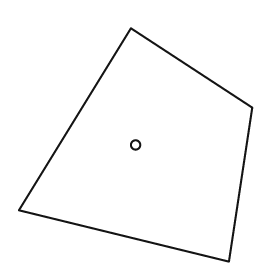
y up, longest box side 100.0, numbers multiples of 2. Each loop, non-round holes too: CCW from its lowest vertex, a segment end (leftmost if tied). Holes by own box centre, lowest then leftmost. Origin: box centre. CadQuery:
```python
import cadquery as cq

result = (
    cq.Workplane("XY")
    .moveTo(40.0, -50.0)
    .lineTo(50.0, 16.0)
    .lineTo(-2.0, 50.0)
    .lineTo(-50.0, -28.0)
    .close()
    .moveTo(0.0, 0.0)
    .circle(2.0)
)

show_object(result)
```